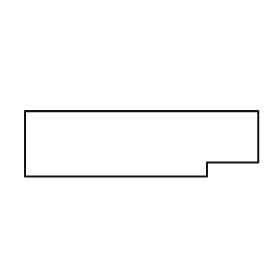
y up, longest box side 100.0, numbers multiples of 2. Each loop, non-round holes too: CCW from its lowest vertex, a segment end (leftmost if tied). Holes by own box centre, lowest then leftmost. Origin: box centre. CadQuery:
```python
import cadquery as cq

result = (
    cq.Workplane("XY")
    .moveTo(-50.0, -14.0)
    .lineTo(28.0, -14.0)
    .lineTo(28.0, -8.0)
    .lineTo(50.0, -8.0)
    .lineTo(50.0, 14.0)
    .lineTo(-50.0, 14.0)
    .close()
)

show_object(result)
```